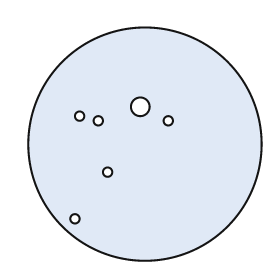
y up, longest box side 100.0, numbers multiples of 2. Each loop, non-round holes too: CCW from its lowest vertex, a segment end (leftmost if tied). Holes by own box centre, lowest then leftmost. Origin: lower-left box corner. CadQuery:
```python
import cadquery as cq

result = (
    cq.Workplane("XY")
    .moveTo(50.0, 50.0)
    .circle(50.0)
    .moveTo(20.0, 18.0)
    .circle(2.0)
    .moveTo(34.0, 38.0)
    .circle(2.0)
    .moveTo(30.0, 60.0)
    .circle(2.0)
    .moveTo(60.0, 60.0)
    .circle(2.0)
    .moveTo(22.0, 62.0)
    .circle(2.0)
    .moveTo(48.0, 66.0)
    .circle(4.0)
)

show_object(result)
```